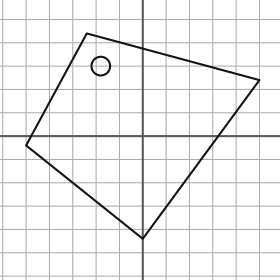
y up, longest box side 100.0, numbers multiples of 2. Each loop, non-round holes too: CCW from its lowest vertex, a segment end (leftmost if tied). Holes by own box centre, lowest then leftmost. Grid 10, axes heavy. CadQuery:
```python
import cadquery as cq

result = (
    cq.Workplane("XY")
    .moveTo(0.0, -44.0)
    .lineTo(50.0, 24.0)
    .lineTo(-24.0, 44.0)
    .lineTo(-50.0, -4.0)
    .close()
    .moveTo(-18.0, 30.0)
    .circle(4.0)
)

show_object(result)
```